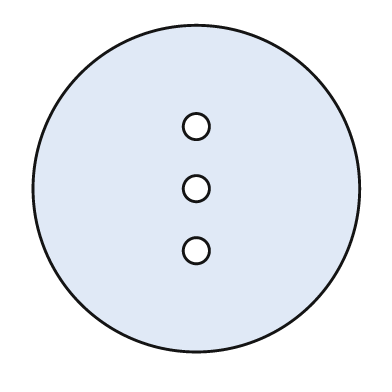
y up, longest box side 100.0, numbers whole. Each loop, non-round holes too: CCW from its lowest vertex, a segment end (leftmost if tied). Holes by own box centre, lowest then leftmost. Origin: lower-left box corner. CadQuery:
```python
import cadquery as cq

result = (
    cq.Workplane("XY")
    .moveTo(50.0, 50.0)
    .circle(50.0)
    .moveTo(50.0, 31.0)
    .circle(4.0)
    .moveTo(50.0, 50.0)
    .circle(4.0)
    .moveTo(50.0, 69.0)
    .circle(4.0)
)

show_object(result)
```